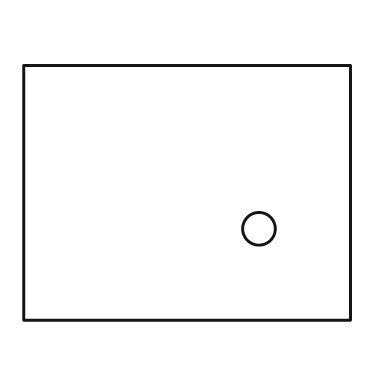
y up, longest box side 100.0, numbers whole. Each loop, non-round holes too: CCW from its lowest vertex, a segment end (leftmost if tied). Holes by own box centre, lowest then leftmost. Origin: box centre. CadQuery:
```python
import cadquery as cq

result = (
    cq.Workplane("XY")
    .moveTo(-50.0, -39.0)
    .lineTo(50.0, -39.0)
    .lineTo(50.0, 39.0)
    .lineTo(-50.0, 39.0)
    .close()
    .moveTo(22.0, -11.0)
    .circle(5.0)
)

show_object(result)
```